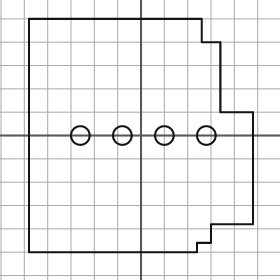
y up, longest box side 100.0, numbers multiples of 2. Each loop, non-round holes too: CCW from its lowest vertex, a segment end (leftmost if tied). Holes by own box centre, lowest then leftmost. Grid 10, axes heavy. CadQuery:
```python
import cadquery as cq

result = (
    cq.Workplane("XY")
    .moveTo(-48.0, -50.0)
    .lineTo(24.0, -50.0)
    .lineTo(24.0, -46.0)
    .lineTo(30.0, -46.0)
    .lineTo(30.0, -38.0)
    .lineTo(48.0, -38.0)
    .lineTo(48.0, 10.0)
    .lineTo(34.0, 10.0)
    .lineTo(34.0, 40.0)
    .lineTo(26.0, 40.0)
    .lineTo(26.0, 50.0)
    .lineTo(-48.0, 50.0)
    .close()
    .moveTo(-26.0, 0.0)
    .circle(4.0)
    .moveTo(-8.0, 0.0)
    .circle(4.0)
    .moveTo(10.0, 0.0)
    .circle(4.0)
    .moveTo(28.0, 0.0)
    .circle(4.0)
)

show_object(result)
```